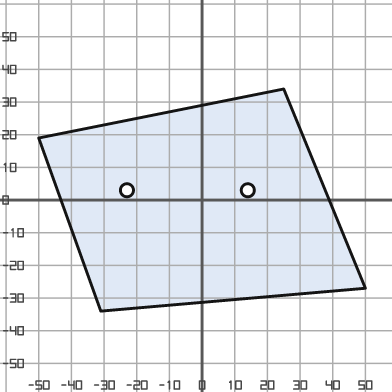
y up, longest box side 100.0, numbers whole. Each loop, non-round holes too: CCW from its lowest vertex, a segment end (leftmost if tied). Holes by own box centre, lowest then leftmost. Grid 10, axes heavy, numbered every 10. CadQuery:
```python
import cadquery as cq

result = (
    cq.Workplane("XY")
    .moveTo(-31.0, -34.0)
    .lineTo(50.0, -27.0)
    .lineTo(25.0, 34.0)
    .lineTo(-50.0, 19.0)
    .close()
    .moveTo(-23.0, 3.0)
    .circle(2.0)
    .moveTo(14.0, 3.0)
    .circle(2.0)
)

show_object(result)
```